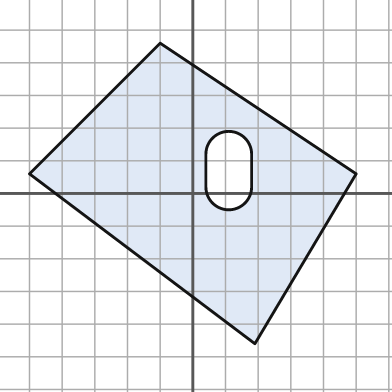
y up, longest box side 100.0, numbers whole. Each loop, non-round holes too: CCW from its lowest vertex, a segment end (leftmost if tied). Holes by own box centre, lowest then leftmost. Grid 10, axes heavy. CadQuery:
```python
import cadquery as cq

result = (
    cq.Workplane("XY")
    .moveTo(19.0, -46.0)
    .lineTo(50.0, 6.0)
    .lineTo(-10.0, 46.0)
    .lineTo(-50.0, 6.0)
    .close()
    .moveTo(4.0, 2.0)
    .threePointArc((11.0, -5.0), (18.0, 2.0))
    .lineTo(18.0, 12.0)
    .threePointArc((11.0, 19.0), (4.0, 12.0))
    .close()
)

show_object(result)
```